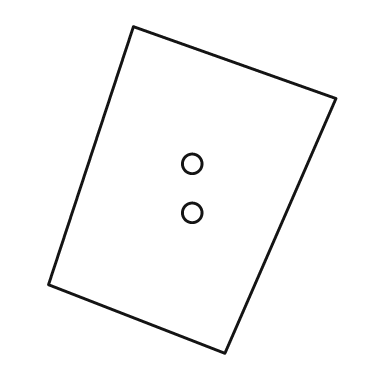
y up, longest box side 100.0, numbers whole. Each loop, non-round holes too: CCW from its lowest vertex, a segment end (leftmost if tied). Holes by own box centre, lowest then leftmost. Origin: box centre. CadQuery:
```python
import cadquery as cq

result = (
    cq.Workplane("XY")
    .moveTo(10.0, -50.0)
    .lineTo(44.0, 28.0)
    .lineTo(-18.0, 50.0)
    .lineTo(-44.0, -29.0)
    .close()
    .moveTo(0.0, -7.0)
    .circle(3.0)
    .moveTo(0.0, 8.0)
    .circle(3.0)
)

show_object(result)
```